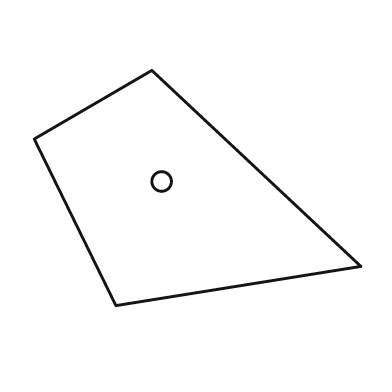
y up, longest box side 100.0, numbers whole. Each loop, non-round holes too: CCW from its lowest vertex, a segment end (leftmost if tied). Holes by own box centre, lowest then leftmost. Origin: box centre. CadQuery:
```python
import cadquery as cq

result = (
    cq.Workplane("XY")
    .moveTo(-25.0, -36.0)
    .lineTo(50.0, -24.0)
    .lineTo(-14.0, 36.0)
    .lineTo(-50.0, 15.0)
    .close()
    .moveTo(-11.0, 2.0)
    .circle(3.0)
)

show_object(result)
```